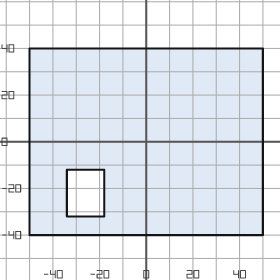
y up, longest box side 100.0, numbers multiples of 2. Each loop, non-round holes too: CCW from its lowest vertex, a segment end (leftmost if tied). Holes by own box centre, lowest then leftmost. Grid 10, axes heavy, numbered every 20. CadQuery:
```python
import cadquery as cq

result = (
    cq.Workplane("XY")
    .moveTo(-50.0, -40.0)
    .lineTo(50.0, -40.0)
    .lineTo(50.0, 40.0)
    .lineTo(-50.0, 40.0)
    .close()
    .moveTo(-34.0, -32.0)
    .lineTo(-18.0, -32.0)
    .lineTo(-18.0, -12.0)
    .lineTo(-34.0, -12.0)
    .close()
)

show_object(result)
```